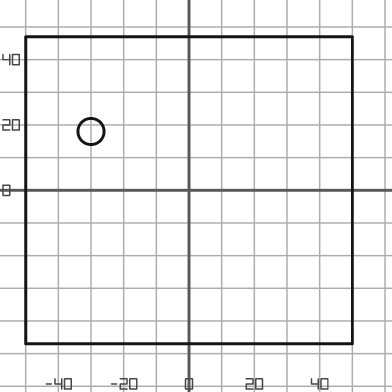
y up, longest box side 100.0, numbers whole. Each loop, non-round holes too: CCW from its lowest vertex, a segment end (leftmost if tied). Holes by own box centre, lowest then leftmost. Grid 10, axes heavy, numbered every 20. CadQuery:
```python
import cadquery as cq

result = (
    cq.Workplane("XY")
    .moveTo(-50.0, -47.0)
    .lineTo(50.0, -47.0)
    .lineTo(50.0, 47.0)
    .lineTo(-50.0, 47.0)
    .close()
    .moveTo(-30.0, 18.0)
    .circle(4.0)
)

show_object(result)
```